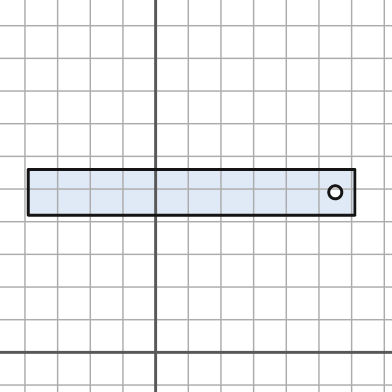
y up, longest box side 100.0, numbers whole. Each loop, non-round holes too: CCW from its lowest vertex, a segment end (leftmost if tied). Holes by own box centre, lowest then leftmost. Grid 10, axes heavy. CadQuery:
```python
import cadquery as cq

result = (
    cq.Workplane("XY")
    .moveTo(-39.0, 42.0)
    .lineTo(61.0, 42.0)
    .lineTo(61.0, 56.0)
    .lineTo(-39.0, 56.0)
    .close()
    .moveTo(55.0, 49.0)
    .circle(2.0)
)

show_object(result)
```